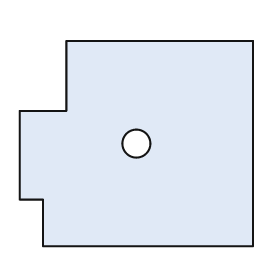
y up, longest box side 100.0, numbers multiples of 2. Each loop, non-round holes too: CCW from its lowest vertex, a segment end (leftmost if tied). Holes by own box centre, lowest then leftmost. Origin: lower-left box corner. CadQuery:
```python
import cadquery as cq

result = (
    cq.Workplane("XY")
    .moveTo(10.0, 0.0)
    .lineTo(100.0, 0.0)
    .lineTo(100.0, 88.0)
    .lineTo(20.0, 88.0)
    .lineTo(20.0, 58.0)
    .lineTo(0.0, 58.0)
    .lineTo(0.0, 20.0)
    .lineTo(10.0, 20.0)
    .close()
    .moveTo(50.0, 44.0)
    .circle(6.0)
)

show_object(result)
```